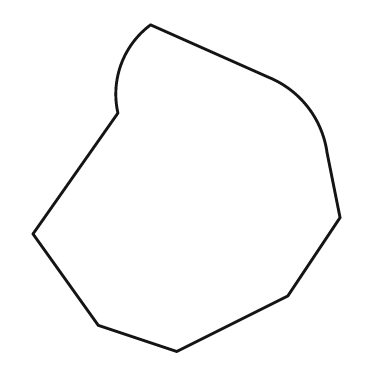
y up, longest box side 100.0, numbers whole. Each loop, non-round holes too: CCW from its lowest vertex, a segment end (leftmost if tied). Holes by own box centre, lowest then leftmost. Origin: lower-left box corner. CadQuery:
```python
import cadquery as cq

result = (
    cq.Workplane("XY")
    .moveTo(44.0, 0.0)
    .lineTo(78.0, 17.0)
    .lineTo(94.0, 41.0)
    .lineTo(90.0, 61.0)
    .threePointArc((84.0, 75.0), (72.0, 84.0))
    .lineTo(36.0, 100.0)
    .threePointArc((27.0, 88.0), (26.0, 73.0))
    .lineTo(0.0, 36.0)
    .lineTo(20.0, 8.0)
    .close()
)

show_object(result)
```